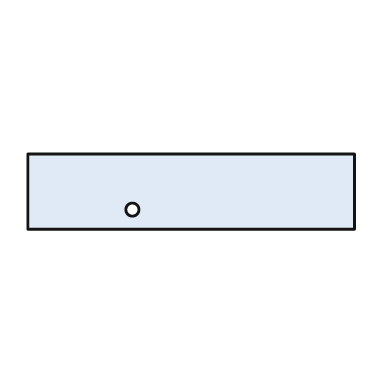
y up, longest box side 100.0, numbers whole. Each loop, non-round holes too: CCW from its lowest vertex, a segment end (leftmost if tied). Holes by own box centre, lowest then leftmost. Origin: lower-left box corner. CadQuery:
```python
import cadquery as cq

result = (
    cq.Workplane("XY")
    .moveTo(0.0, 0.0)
    .lineTo(100.0, 0.0)
    .lineTo(100.0, 23.0)
    .lineTo(0.0, 23.0)
    .close()
    .moveTo(32.0, 6.0)
    .circle(2.0)
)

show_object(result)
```